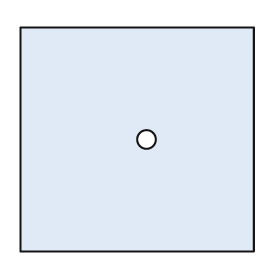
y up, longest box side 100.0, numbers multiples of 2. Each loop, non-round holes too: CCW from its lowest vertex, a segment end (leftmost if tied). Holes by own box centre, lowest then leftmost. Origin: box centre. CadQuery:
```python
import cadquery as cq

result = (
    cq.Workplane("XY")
    .moveTo(-50.0, -48.0)
    .lineTo(50.0, -48.0)
    .lineTo(50.0, 48.0)
    .lineTo(-50.0, 48.0)
    .close()
    .moveTo(4.0, 0.0)
    .circle(4.0)
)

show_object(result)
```